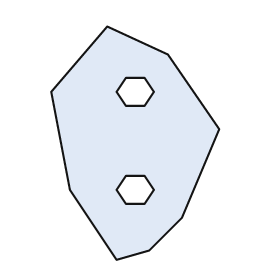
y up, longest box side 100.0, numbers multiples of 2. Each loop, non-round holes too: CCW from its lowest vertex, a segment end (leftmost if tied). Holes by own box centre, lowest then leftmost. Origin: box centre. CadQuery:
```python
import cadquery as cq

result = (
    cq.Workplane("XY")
    .moveTo(-8.0, -50.0)
    .lineTo(6.0, -46.0)
    .lineTo(20.0, -32.0)
    .lineTo(36.0, 6.0)
    .lineTo(14.0, 38.0)
    .lineTo(-12.0, 50.0)
    .lineTo(-36.0, 22.0)
    .lineTo(-28.0, -20.0)
    .close()
    .moveTo(-4.0, -26.0)
    .lineTo(4.0, -26.0)
    .lineTo(8.0, -20.0)
    .lineTo(4.0, -14.0)
    .lineTo(-4.0, -14.0)
    .lineTo(-8.0, -20.0)
    .close()
    .moveTo(-4.0, 16.0)
    .lineTo(4.0, 16.0)
    .lineTo(8.0, 22.0)
    .lineTo(4.0, 28.0)
    .lineTo(-4.0, 28.0)
    .lineTo(-8.0, 22.0)
    .close()
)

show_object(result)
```